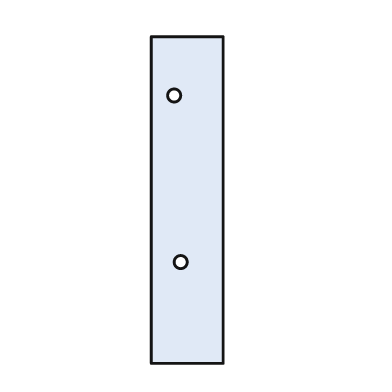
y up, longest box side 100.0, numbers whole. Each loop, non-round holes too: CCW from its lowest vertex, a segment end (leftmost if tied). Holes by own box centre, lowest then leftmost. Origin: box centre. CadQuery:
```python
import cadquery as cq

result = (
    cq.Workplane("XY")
    .moveTo(-11.0, -50.0)
    .lineTo(11.0, -50.0)
    .lineTo(11.0, 50.0)
    .lineTo(-11.0, 50.0)
    .close()
    .moveTo(-2.0, -19.0)
    .circle(2.0)
    .moveTo(-4.0, 32.0)
    .circle(2.0)
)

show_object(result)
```